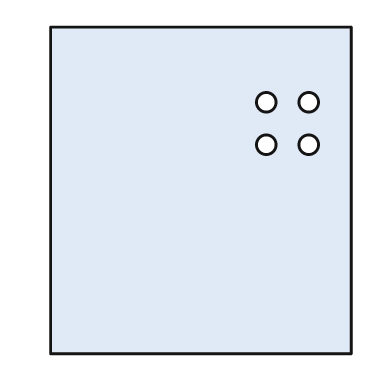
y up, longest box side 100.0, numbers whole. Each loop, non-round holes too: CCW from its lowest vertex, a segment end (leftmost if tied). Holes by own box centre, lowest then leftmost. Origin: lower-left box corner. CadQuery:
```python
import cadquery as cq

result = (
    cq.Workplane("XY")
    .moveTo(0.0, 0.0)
    .lineTo(92.0, 0.0)
    .lineTo(92.0, 100.0)
    .lineTo(0.0, 100.0)
    .close()
    .moveTo(66.0, 64.0)
    .circle(3.0)
    .moveTo(79.0, 64.0)
    .circle(3.0)
    .moveTo(66.0, 77.0)
    .circle(3.0)
    .moveTo(79.0, 77.0)
    .circle(3.0)
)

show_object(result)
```